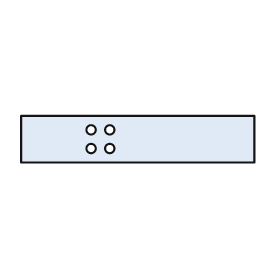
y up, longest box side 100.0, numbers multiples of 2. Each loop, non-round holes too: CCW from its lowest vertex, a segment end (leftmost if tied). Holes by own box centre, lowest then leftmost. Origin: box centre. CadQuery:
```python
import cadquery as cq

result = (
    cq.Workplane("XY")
    .moveTo(-50.0, -10.0)
    .lineTo(50.0, -10.0)
    .lineTo(50.0, 10.0)
    .lineTo(-50.0, 10.0)
    .close()
    .moveTo(-20.0, -4.0)
    .circle(2.0)
    .moveTo(-12.0, -4.0)
    .circle(2.0)
    .moveTo(-20.0, 4.0)
    .circle(2.0)
    .moveTo(-12.0, 4.0)
    .circle(2.0)
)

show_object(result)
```